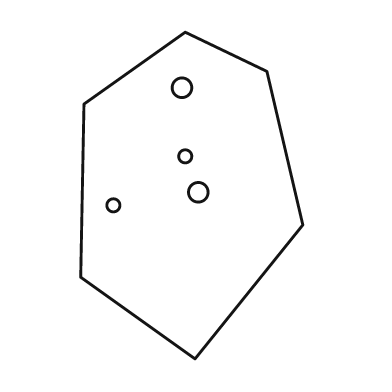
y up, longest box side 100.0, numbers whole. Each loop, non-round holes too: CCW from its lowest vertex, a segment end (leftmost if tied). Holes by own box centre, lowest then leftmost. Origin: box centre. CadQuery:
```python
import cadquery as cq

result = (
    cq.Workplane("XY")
    .moveTo(1.0, -50.0)
    .lineTo(34.0, -9.0)
    .lineTo(23.0, 38.0)
    .lineTo(-2.0, 50.0)
    .lineTo(-33.0, 28.0)
    .lineTo(-34.0, -25.0)
    .close()
    .moveTo(-24.0, -3.0)
    .circle(2.0)
    .moveTo(2.0, 1.0)
    .circle(3.0)
    .moveTo(-2.0, 12.0)
    .circle(2.0)
    .moveTo(-3.0, 33.0)
    .circle(3.0)
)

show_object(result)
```